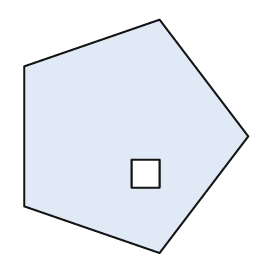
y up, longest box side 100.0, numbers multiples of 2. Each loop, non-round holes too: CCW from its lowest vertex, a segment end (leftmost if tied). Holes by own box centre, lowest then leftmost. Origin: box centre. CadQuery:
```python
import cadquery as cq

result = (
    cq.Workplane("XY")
    .moveTo(10.0, -50.0)
    .lineTo(48.0, 0.0)
    .lineTo(10.0, 50.0)
    .lineTo(-48.0, 30.0)
    .lineTo(-48.0, -30.0)
    .close()
    .moveTo(-2.0, -22.0)
    .lineTo(10.0, -22.0)
    .lineTo(10.0, -10.0)
    .lineTo(-2.0, -10.0)
    .close()
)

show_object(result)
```